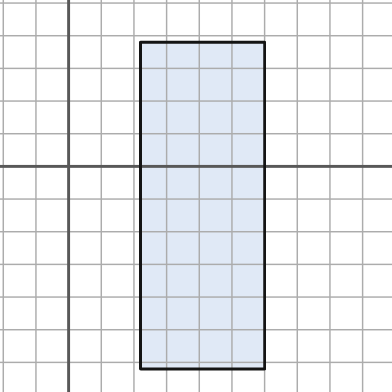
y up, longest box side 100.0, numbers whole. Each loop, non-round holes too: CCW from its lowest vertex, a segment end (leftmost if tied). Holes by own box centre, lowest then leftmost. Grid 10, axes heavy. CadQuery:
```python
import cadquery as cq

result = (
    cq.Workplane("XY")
    .moveTo(22.0, -62.0)
    .lineTo(60.0, -62.0)
    .lineTo(60.0, 38.0)
    .lineTo(22.0, 38.0)
    .close()
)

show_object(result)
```